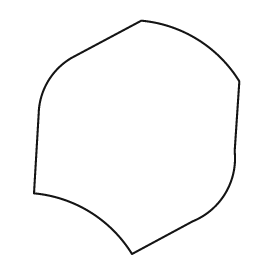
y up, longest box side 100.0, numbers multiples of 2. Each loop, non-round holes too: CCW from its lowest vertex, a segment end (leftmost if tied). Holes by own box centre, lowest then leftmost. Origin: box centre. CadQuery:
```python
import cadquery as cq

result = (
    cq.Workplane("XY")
    .moveTo(-2.0, -50.0)
    .lineTo(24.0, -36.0)
    .threePointArc((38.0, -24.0), (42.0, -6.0))
    .lineTo(44.0, 24.0)
    .threePointArc((26.0, 42.0), (2.0, 50.0))
    .lineTo(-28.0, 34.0)
    .threePointArc((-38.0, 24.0), (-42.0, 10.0))
    .lineTo(-44.0, -24.0)
    .threePointArc((-20.0, -32.0), (-2.0, -50.0))
    .close()
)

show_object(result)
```